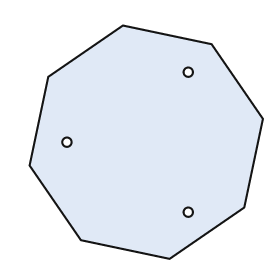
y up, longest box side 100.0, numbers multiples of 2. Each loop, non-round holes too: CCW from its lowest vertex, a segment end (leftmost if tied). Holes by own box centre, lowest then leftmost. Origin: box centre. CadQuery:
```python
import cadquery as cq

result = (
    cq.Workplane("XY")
    .moveTo(10.0, -50.0)
    .lineTo(42.0, -28.0)
    .lineTo(50.0, 10.0)
    .lineTo(28.0, 42.0)
    .lineTo(-10.0, 50.0)
    .lineTo(-42.0, 28.0)
    .lineTo(-50.0, -10.0)
    .lineTo(-28.0, -42.0)
    .close()
    .moveTo(18.0, -30.0)
    .circle(2.0)
    .moveTo(-34.0, 0.0)
    .circle(2.0)
    .moveTo(18.0, 30.0)
    .circle(2.0)
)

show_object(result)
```